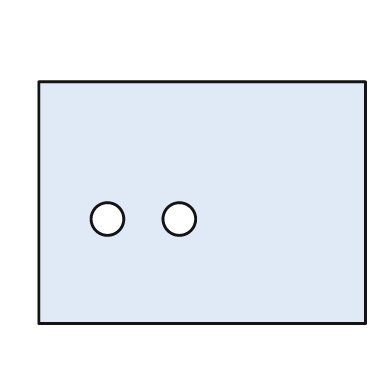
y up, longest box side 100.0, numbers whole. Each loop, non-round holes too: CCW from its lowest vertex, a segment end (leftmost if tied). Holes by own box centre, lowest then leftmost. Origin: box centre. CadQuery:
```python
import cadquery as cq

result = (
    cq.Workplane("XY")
    .moveTo(-50.0, -37.0)
    .lineTo(50.0, -37.0)
    .lineTo(50.0, 37.0)
    .lineTo(-50.0, 37.0)
    .close()
    .moveTo(-29.0, -5.0)
    .circle(5.0)
    .moveTo(-7.0, -5.0)
    .circle(5.0)
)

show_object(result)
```